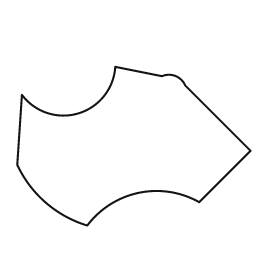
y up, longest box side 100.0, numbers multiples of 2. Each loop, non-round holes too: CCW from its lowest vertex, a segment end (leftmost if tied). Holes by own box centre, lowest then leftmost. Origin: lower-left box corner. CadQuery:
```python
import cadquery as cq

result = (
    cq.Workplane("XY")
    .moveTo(30.0, 0.0)
    .threePointArc((52.0, 14.0), (78.0, 10.0))
    .lineTo(100.0, 32.0)
    .lineTo(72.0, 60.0)
    .threePointArc((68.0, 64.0), (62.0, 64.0))
    .lineTo(42.0, 68.0)
    .threePointArc((26.0, 48.0), (2.0, 56.0))
    .lineTo(0.0, 26.0)
    .threePointArc((12.0, 10.0), (30.0, 0.0))
    .close()
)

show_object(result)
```